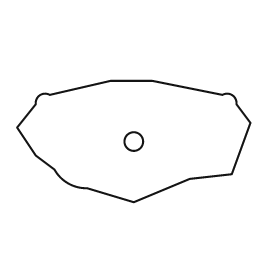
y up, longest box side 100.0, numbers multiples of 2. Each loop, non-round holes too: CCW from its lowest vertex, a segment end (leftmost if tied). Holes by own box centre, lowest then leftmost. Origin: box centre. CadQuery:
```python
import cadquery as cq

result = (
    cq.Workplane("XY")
    .moveTo(0.0, -26.0)
    .lineTo(24.0, -16.0)
    .lineTo(42.0, -14.0)
    .lineTo(50.0, 8.0)
    .lineTo(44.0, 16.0)
    .threePointArc((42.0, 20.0), (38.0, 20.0))
    .lineTo(8.0, 26.0)
    .lineTo(-10.0, 26.0)
    .lineTo(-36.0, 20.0)
    .threePointArc((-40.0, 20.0), (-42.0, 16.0))
    .lineTo(-50.0, 6.0)
    .lineTo(-42.0, -6.0)
    .lineTo(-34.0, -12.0)
    .threePointArc((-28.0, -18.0), (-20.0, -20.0))
    .close()
    .moveTo(0.0, 0.0)
    .circle(4.0)
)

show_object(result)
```